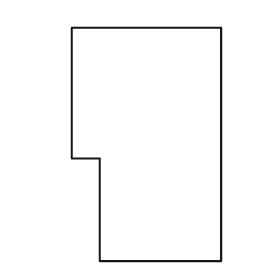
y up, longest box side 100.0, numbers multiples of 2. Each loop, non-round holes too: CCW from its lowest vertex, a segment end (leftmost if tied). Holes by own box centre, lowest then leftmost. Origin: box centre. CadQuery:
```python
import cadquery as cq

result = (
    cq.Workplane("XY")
    .moveTo(-20.0, -50.0)
    .lineTo(32.0, -50.0)
    .lineTo(32.0, 50.0)
    .lineTo(-32.0, 50.0)
    .lineTo(-32.0, -6.0)
    .lineTo(-20.0, -6.0)
    .close()
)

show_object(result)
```